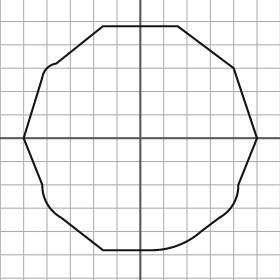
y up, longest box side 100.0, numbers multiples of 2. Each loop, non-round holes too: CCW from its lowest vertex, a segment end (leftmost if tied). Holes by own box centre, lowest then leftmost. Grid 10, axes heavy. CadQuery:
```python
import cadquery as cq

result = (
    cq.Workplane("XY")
    .moveTo(-16.0, -48.0)
    .lineTo(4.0, -48.0)
    .threePointArc((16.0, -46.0), (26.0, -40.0))
    .lineTo(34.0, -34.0)
    .threePointArc((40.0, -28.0), (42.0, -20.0))
    .lineTo(50.0, 0.0)
    .lineTo(40.0, 30.0)
    .lineTo(16.0, 48.0)
    .lineTo(-16.0, 48.0)
    .lineTo(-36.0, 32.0)
    .threePointArc((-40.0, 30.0), (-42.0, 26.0))
    .lineTo(-50.0, 0.0)
    .lineTo(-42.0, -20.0)
    .threePointArc((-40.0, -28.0), (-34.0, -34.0))
    .close()
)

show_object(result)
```